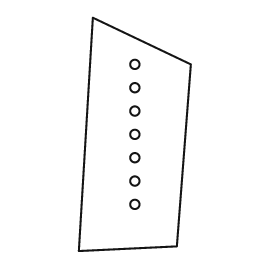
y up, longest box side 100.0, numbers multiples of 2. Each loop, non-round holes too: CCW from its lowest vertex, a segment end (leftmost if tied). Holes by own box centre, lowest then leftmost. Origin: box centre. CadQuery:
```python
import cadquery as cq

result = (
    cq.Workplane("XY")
    .moveTo(-24.0, -50.0)
    .lineTo(18.0, -48.0)
    .lineTo(24.0, 30.0)
    .lineTo(-18.0, 50.0)
    .close()
    .moveTo(0.0, -30.0)
    .circle(2.0)
    .moveTo(0.0, -20.0)
    .circle(2.0)
    .moveTo(0.0, -10.0)
    .circle(2.0)
    .moveTo(0.0, 0.0)
    .circle(2.0)
    .moveTo(0.0, 10.0)
    .circle(2.0)
    .moveTo(0.0, 20.0)
    .circle(2.0)
    .moveTo(0.0, 30.0)
    .circle(2.0)
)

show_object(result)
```